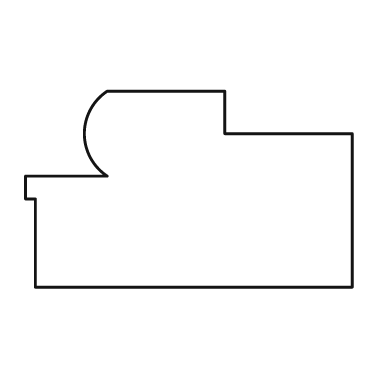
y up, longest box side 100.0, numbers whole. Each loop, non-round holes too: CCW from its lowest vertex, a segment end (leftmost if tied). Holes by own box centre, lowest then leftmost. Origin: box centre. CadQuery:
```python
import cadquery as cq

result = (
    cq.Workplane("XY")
    .moveTo(-47.0, -30.0)
    .lineTo(50.0, -30.0)
    .lineTo(50.0, 17.0)
    .lineTo(11.0, 17.0)
    .lineTo(11.0, 30.0)
    .lineTo(-25.0, 30.0)
    .threePointArc((-32.0, 17.0), (-25.0, 4.0))
    .lineTo(-50.0, 4.0)
    .lineTo(-50.0, -3.0)
    .lineTo(-47.0, -3.0)
    .close()
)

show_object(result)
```